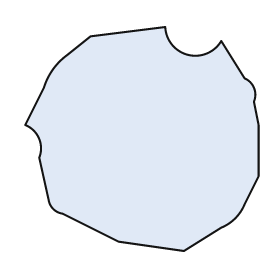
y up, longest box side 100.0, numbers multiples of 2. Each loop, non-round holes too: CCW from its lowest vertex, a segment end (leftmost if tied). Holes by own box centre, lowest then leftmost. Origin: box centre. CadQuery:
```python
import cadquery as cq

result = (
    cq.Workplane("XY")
    .moveTo(18.0, -48.0)
    .lineTo(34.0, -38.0)
    .threePointArc((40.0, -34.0), (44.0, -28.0))
    .lineTo(50.0, -16.0)
    .lineTo(50.0, 6.0)
    .lineTo(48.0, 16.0)
    .threePointArc((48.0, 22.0), (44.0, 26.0))
    .lineTo(34.0, 42.0)
    .threePointArc((20.0, 36.0), (10.0, 48.0))
    .lineTo(-22.0, 44.0)
    .lineTo(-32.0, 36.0)
    .threePointArc((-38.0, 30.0), (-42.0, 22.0))
    .lineTo(-50.0, 6.0)
    .threePointArc((-44.0, 0.0), (-44.0, -8.0))
    .lineTo(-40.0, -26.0)
    .threePointArc((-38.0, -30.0), (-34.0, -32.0))
    .lineTo(-10.0, -44.0)
    .close()
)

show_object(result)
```